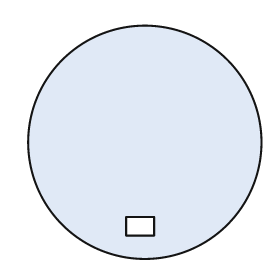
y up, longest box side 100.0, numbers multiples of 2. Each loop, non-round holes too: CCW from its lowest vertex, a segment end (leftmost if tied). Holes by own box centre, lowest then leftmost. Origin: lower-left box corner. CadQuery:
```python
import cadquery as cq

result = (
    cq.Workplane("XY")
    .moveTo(50.0, 50.0)
    .circle(50.0)
    .moveTo(42.0, 10.0)
    .lineTo(54.0, 10.0)
    .lineTo(54.0, 18.0)
    .lineTo(42.0, 18.0)
    .close()
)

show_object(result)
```